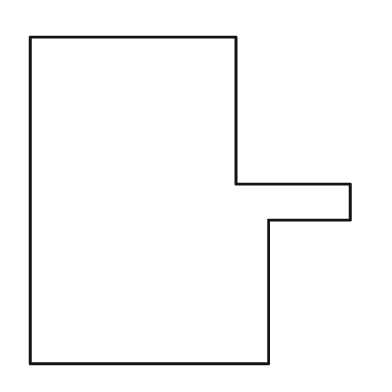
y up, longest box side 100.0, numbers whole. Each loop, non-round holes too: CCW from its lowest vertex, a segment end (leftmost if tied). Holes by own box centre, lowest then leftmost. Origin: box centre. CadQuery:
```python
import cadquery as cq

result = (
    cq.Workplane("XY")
    .moveTo(-49.0, -50.0)
    .lineTo(24.0, -50.0)
    .lineTo(24.0, -6.0)
    .lineTo(49.0, -6.0)
    .lineTo(49.0, 5.0)
    .lineTo(14.0, 5.0)
    .lineTo(14.0, 50.0)
    .lineTo(-49.0, 50.0)
    .close()
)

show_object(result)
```